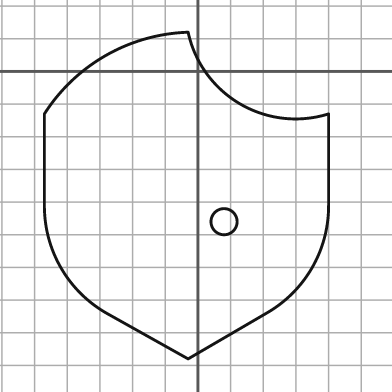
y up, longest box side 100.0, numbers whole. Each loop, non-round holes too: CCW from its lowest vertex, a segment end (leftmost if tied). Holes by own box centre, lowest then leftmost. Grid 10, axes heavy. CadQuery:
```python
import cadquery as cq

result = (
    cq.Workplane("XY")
    .moveTo(-3.0, -88.0)
    .lineTo(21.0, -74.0)
    .threePointArc((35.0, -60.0), (40.0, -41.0))
    .lineTo(40.0, -13.0)
    .threePointArc((13.0, -10.0), (-3.0, 12.0))
    .threePointArc((-28.0, 5.0), (-47.0, -13.0))
    .lineTo(-47.0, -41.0)
    .threePointArc((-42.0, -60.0), (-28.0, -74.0))
    .close()
    .moveTo(8.0, -46.0)
    .circle(4.0)
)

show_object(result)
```